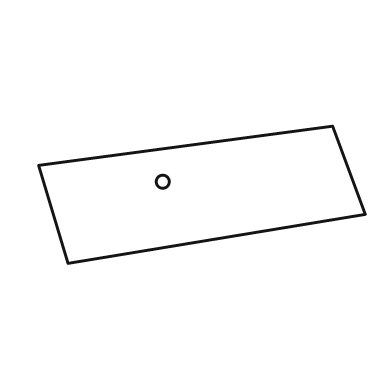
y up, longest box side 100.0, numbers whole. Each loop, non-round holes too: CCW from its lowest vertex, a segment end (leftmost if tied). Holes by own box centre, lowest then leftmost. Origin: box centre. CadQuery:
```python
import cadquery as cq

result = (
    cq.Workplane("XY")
    .moveTo(-41.0, -21.0)
    .lineTo(50.0, -6.0)
    .lineTo(40.0, 21.0)
    .lineTo(-50.0, 9.0)
    .close()
    .moveTo(-12.0, 4.0)
    .circle(2.0)
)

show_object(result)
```